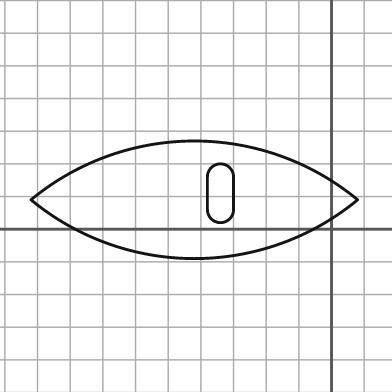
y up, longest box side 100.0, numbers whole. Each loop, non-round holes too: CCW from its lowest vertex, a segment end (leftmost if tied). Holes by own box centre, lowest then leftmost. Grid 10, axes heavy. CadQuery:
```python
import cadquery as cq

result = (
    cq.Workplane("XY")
    .moveTo(-92.0, 9.0)
    .threePointArc((-42.0, -9.0), (8.0, 9.0))
    .threePointArc((-42.0, 27.0), (-92.0, 9.0))
    .close()
    .moveTo(-38.0, 6.0)
    .threePointArc((-34.0, 2.0), (-30.0, 6.0))
    .lineTo(-30.0, 16.0)
    .threePointArc((-34.0, 20.0), (-38.0, 16.0))
    .close()
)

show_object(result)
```